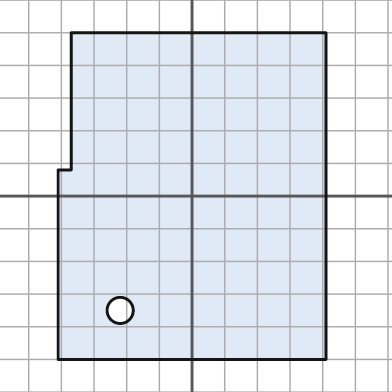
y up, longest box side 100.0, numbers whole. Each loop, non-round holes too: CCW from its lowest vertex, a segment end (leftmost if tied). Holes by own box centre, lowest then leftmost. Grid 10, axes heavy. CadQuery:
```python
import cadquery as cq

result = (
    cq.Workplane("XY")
    .moveTo(-41.0, -50.0)
    .lineTo(41.0, -50.0)
    .lineTo(41.0, 50.0)
    .lineTo(-37.0, 50.0)
    .lineTo(-37.0, 8.0)
    .lineTo(-41.0, 8.0)
    .close()
    .moveTo(-22.0, -35.0)
    .circle(4.0)
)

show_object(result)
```